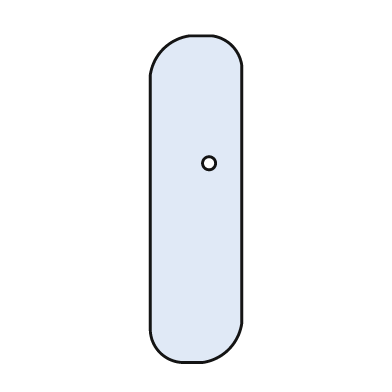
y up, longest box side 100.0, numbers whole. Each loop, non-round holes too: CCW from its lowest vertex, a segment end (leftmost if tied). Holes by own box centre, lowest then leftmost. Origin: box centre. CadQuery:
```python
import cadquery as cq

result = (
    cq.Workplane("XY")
    .moveTo(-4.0, -50.0)
    .lineTo(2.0, -50.0)
    .threePointArc((10.0, -46.0), (14.0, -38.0))
    .lineTo(14.0, 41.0)
    .threePointArc((11.0, 47.0), (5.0, 50.0))
    .lineTo(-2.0, 50.0)
    .threePointArc((-10.0, 46.0), (-14.0, 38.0))
    .lineTo(-14.0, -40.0)
    .threePointArc((-11.0, -47.0), (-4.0, -50.0))
    .close()
    .moveTo(4.0, 11.0)
    .circle(2.0)
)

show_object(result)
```